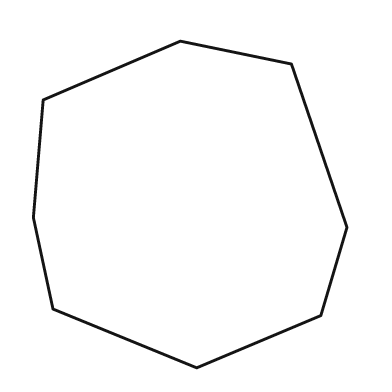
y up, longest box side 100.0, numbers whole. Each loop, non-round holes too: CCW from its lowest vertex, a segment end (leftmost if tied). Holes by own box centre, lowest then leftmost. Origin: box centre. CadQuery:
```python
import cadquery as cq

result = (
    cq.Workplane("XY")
    .moveTo(2.0, -50.0)
    .lineTo(40.0, -34.0)
    .lineTo(48.0, -7.0)
    .lineTo(31.0, 43.0)
    .lineTo(-3.0, 50.0)
    .lineTo(-45.0, 32.0)
    .lineTo(-48.0, -4.0)
    .lineTo(-42.0, -32.0)
    .close()
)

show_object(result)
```